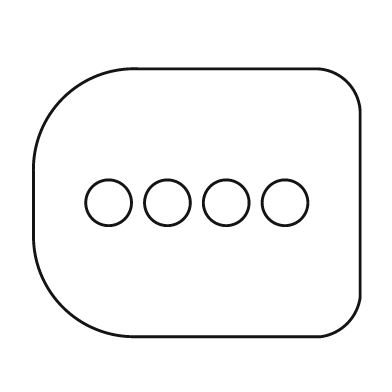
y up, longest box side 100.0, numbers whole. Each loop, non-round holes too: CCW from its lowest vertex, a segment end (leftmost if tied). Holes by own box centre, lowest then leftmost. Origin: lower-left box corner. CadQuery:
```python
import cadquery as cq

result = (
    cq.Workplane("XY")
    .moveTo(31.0, 0.0)
    .lineTo(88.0, 0.0)
    .threePointArc((96.0, 4.0), (100.0, 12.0))
    .lineTo(100.0, 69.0)
    .threePointArc((96.0, 78.0), (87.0, 82.0))
    .lineTo(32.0, 82.0)
    .threePointArc((9.0, 73.0), (0.0, 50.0))
    .lineTo(0.0, 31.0)
    .threePointArc((9.0, 9.0), (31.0, 0.0))
    .close()
    .moveTo(23.0, 41.0)
    .circle(7.0)
    .moveTo(41.0, 41.0)
    .circle(7.0)
    .moveTo(59.0, 41.0)
    .circle(7.0)
    .moveTo(77.0, 41.0)
    .circle(7.0)
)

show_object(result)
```